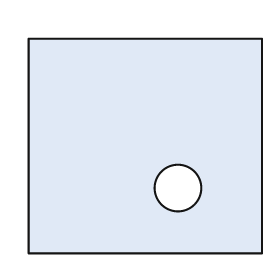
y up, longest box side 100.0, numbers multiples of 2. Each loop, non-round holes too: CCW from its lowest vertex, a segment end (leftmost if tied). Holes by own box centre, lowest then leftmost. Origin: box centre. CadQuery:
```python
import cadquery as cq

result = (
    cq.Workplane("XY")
    .moveTo(-50.0, -46.0)
    .lineTo(50.0, -46.0)
    .lineTo(50.0, 46.0)
    .lineTo(-50.0, 46.0)
    .close()
    .moveTo(14.0, -18.0)
    .circle(10.0)
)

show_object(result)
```